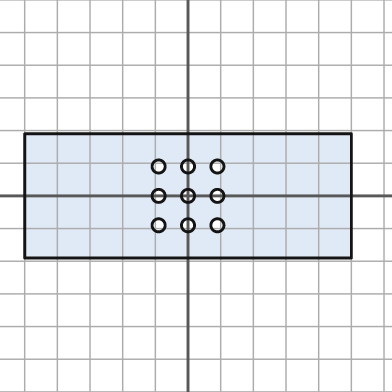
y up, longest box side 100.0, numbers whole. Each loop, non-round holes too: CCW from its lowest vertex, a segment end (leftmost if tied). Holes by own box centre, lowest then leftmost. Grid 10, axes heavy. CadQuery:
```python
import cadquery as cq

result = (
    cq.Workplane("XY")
    .moveTo(-50.0, -19.0)
    .lineTo(50.0, -19.0)
    .lineTo(50.0, 19.0)
    .lineTo(-50.0, 19.0)
    .close()
    .moveTo(-9.0, -9.0)
    .circle(2.0)
    .moveTo(0.0, -9.0)
    .circle(2.0)
    .moveTo(9.0, -9.0)
    .circle(2.0)
    .moveTo(-9.0, 0.0)
    .circle(2.0)
    .moveTo(0.0, 0.0)
    .circle(2.0)
    .moveTo(9.0, 0.0)
    .circle(2.0)
    .moveTo(-9.0, 9.0)
    .circle(2.0)
    .moveTo(0.0, 9.0)
    .circle(2.0)
    .moveTo(9.0, 9.0)
    .circle(2.0)
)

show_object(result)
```